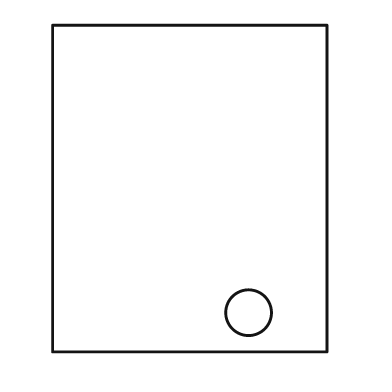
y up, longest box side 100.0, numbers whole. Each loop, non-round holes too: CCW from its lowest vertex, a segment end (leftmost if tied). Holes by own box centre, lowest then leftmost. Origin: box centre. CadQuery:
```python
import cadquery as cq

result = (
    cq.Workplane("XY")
    .moveTo(-42.0, -50.0)
    .lineTo(42.0, -50.0)
    .lineTo(42.0, 50.0)
    .lineTo(-42.0, 50.0)
    .close()
    .moveTo(18.0, -38.0)
    .circle(7.0)
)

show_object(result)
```